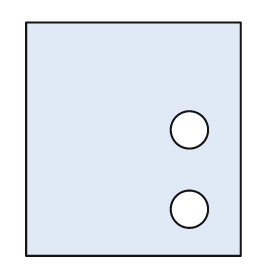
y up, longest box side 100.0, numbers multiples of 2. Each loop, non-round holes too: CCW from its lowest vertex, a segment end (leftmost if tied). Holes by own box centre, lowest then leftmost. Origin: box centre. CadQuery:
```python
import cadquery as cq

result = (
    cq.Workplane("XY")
    .moveTo(-46.0, -50.0)
    .lineTo(46.0, -50.0)
    .lineTo(46.0, 50.0)
    .lineTo(-46.0, 50.0)
    .close()
    .moveTo(24.0, -30.0)
    .circle(8.0)
    .moveTo(24.0, 4.0)
    .circle(8.0)
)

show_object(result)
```